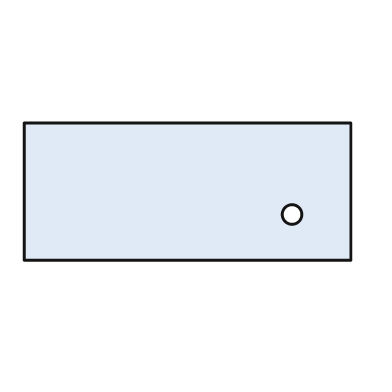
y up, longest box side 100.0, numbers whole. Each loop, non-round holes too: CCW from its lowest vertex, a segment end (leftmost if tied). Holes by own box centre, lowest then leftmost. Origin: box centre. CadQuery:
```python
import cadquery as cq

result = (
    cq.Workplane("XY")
    .moveTo(-50.0, -21.0)
    .lineTo(50.0, -21.0)
    .lineTo(50.0, 21.0)
    .lineTo(-50.0, 21.0)
    .close()
    .moveTo(32.0, -7.0)
    .circle(3.0)
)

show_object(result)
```